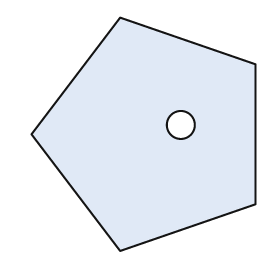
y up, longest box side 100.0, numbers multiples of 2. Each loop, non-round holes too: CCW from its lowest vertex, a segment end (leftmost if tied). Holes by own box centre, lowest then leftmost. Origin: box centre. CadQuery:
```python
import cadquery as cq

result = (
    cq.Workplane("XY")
    .moveTo(-10.0, -50.0)
    .lineTo(48.0, -30.0)
    .lineTo(48.0, 30.0)
    .lineTo(-10.0, 50.0)
    .lineTo(-48.0, 0.0)
    .close()
    .moveTo(16.0, 4.0)
    .circle(6.0)
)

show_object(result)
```